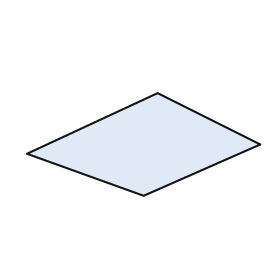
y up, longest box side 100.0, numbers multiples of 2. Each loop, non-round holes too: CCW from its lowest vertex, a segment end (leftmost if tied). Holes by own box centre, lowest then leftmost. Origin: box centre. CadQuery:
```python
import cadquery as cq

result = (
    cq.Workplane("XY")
    .moveTo(0.0, -22.0)
    .lineTo(50.0, 0.0)
    .lineTo(6.0, 22.0)
    .lineTo(-50.0, -4.0)
    .close()
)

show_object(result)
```